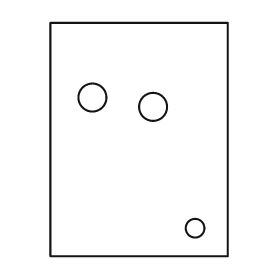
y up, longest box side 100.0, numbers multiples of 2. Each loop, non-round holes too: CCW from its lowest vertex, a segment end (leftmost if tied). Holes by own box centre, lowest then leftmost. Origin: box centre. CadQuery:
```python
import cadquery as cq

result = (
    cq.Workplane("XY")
    .moveTo(-38.0, -50.0)
    .lineTo(38.0, -50.0)
    .lineTo(38.0, 50.0)
    .lineTo(-38.0, 50.0)
    .close()
    .moveTo(24.0, -38.0)
    .circle(4.0)
    .moveTo(6.0, 14.0)
    .circle(6.0)
    .moveTo(-20.0, 18.0)
    .circle(6.0)
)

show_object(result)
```